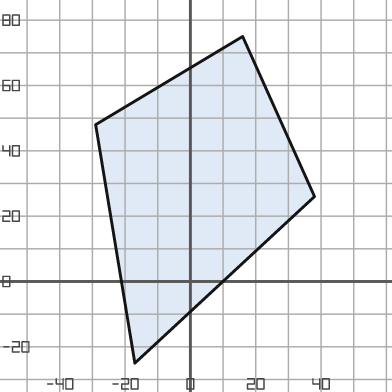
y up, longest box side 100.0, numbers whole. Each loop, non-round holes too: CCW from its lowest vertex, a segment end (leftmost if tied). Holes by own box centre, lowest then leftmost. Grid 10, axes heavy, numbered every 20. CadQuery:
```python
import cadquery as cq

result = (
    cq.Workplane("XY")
    .moveTo(-17.0, -25.0)
    .lineTo(38.0, 26.0)
    .lineTo(16.0, 75.0)
    .lineTo(-29.0, 48.0)
    .close()
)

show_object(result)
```